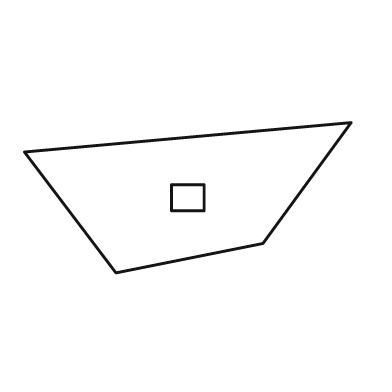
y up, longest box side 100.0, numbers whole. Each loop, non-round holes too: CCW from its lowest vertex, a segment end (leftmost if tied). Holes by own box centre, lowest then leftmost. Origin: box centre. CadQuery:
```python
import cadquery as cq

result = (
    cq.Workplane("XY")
    .moveTo(-22.0, -23.0)
    .lineTo(23.0, -14.0)
    .lineTo(50.0, 23.0)
    .lineTo(-50.0, 14.0)
    .close()
    .moveTo(-5.0, -4.0)
    .lineTo(5.0, -4.0)
    .lineTo(5.0, 4.0)
    .lineTo(-5.0, 4.0)
    .close()
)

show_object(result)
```